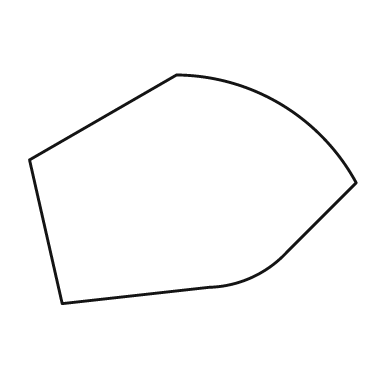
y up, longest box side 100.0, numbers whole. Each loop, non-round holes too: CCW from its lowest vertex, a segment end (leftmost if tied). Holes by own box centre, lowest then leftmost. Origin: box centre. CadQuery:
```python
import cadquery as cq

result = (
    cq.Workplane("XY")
    .moveTo(-40.0, -35.0)
    .lineTo(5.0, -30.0)
    .threePointArc((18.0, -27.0), (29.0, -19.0))
    .lineTo(50.0, 2.0)
    .threePointArc((27.0, 26.0), (-5.0, 35.0))
    .lineTo(-50.0, 9.0)
    .close()
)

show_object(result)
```